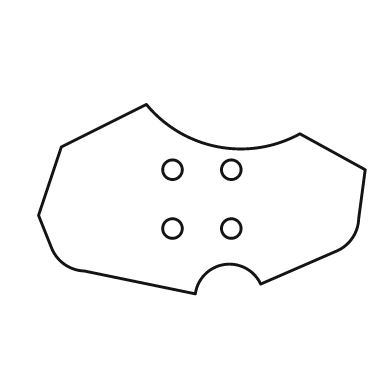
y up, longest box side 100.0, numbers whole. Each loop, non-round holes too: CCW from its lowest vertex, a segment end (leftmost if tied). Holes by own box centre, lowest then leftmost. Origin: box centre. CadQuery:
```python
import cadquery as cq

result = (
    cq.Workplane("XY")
    .moveTo(-2.0, -29.0)
    .threePointArc((7.0, -20.0), (18.0, -26.0))
    .lineTo(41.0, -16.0)
    .threePointArc((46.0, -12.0), (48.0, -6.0))
    .lineTo(50.0, 9.0)
    .lineTo(30.0, 20.0)
    .threePointArc((5.0, 16.0), (-17.0, 29.0))
    .lineTo(-43.0, 16.0)
    .lineTo(-50.0, -5.0)
    .lineTo(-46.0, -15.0)
    .threePointArc((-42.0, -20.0), (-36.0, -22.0))
    .close()
    .moveTo(-9.0, -9.0)
    .circle(3.0)
    .moveTo(9.0, -9.0)
    .circle(3.0)
    .moveTo(-9.0, 9.0)
    .circle(3.0)
    .moveTo(9.0, 9.0)
    .circle(3.0)
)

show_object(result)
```